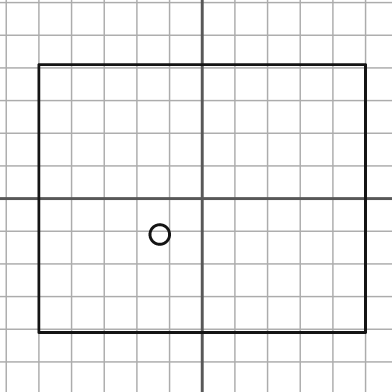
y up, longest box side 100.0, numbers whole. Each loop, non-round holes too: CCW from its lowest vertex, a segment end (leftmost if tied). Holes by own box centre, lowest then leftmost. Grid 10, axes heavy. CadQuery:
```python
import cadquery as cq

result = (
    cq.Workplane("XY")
    .moveTo(-50.0, -41.0)
    .lineTo(50.0, -41.0)
    .lineTo(50.0, 41.0)
    .lineTo(-50.0, 41.0)
    .close()
    .moveTo(-13.0, -11.0)
    .circle(3.0)
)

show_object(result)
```